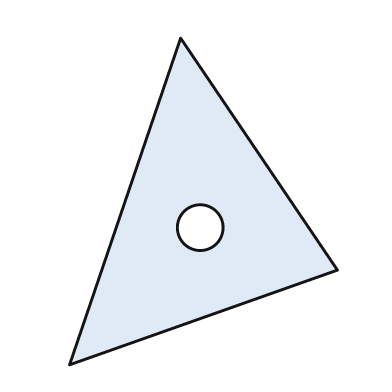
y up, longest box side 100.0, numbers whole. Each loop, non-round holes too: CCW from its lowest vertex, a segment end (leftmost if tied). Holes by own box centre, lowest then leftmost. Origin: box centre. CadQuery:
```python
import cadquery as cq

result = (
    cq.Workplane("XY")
    .moveTo(-41.0, -50.0)
    .lineTo(41.0, -21.0)
    .lineTo(-7.0, 50.0)
    .close()
    .moveTo(-1.0, -8.0)
    .circle(7.0)
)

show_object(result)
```